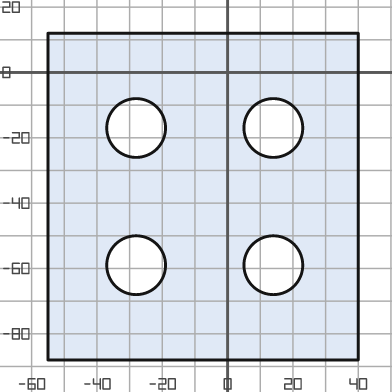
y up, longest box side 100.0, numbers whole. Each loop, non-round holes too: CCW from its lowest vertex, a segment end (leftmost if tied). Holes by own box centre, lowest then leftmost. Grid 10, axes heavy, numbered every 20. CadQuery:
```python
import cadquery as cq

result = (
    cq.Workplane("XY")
    .moveTo(-55.0, -88.0)
    .lineTo(40.0, -88.0)
    .lineTo(40.0, 12.0)
    .lineTo(-55.0, 12.0)
    .close()
    .moveTo(-28.0, -59.0)
    .circle(9.0)
    .moveTo(14.0, -59.0)
    .circle(9.0)
    .moveTo(-28.0, -17.0)
    .circle(9.0)
    .moveTo(14.0, -17.0)
    .circle(9.0)
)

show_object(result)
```